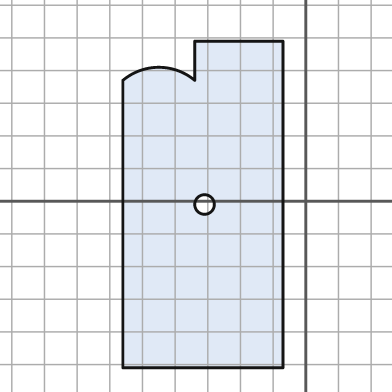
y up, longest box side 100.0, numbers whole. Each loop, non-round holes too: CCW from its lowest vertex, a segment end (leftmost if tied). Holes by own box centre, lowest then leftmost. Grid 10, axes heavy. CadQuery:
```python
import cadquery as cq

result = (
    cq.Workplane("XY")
    .moveTo(-56.0, -51.0)
    .lineTo(-7.0, -51.0)
    .lineTo(-7.0, 49.0)
    .lineTo(-34.0, 49.0)
    .lineTo(-34.0, 37.0)
    .threePointArc((-45.0, 41.0), (-56.0, 37.0))
    .close()
    .moveTo(-31.0, -1.0)
    .circle(3.0)
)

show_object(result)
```